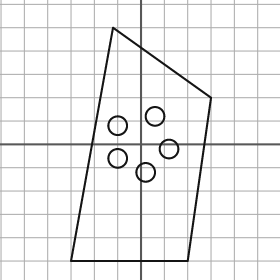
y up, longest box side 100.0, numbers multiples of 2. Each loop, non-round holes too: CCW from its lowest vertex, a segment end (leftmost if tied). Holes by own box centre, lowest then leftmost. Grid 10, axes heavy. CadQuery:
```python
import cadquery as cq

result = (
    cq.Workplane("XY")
    .moveTo(-30.0, -50.0)
    .lineTo(20.0, -50.0)
    .lineTo(30.0, 20.0)
    .lineTo(-12.0, 50.0)
    .close()
    .moveTo(2.0, -12.0)
    .circle(4.0)
    .moveTo(-10.0, -6.0)
    .circle(4.0)
    .moveTo(12.0, -2.0)
    .circle(4.0)
    .moveTo(-10.0, 8.0)
    .circle(4.0)
    .moveTo(6.0, 12.0)
    .circle(4.0)
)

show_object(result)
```